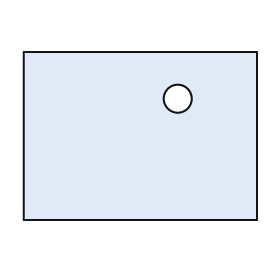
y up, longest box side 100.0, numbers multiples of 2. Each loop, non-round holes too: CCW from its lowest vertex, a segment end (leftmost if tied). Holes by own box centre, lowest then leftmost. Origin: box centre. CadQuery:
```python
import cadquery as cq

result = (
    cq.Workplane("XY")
    .moveTo(-50.0, -36.0)
    .lineTo(50.0, -36.0)
    .lineTo(50.0, 36.0)
    .lineTo(-50.0, 36.0)
    .close()
    .moveTo(16.0, 16.0)
    .circle(6.0)
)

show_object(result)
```